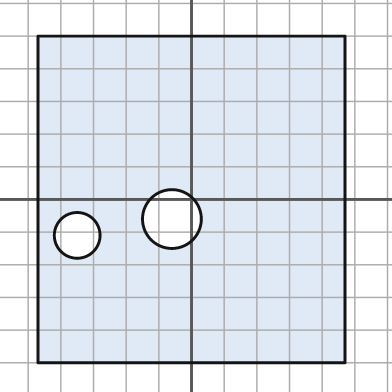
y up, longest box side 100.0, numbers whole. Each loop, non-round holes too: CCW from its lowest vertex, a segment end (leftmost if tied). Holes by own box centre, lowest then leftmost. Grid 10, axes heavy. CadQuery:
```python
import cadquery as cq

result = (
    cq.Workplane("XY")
    .moveTo(-47.0, -50.0)
    .lineTo(47.0, -50.0)
    .lineTo(47.0, 50.0)
    .lineTo(-47.0, 50.0)
    .close()
    .moveTo(-35.0, -11.0)
    .circle(7.0)
    .moveTo(-6.0, -6.0)
    .circle(9.0)
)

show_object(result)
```